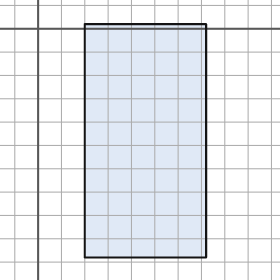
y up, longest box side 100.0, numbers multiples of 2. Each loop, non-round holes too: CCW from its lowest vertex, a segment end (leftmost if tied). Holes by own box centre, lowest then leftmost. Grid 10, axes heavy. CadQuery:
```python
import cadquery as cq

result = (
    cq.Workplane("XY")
    .moveTo(20.0, -98.0)
    .lineTo(72.0, -98.0)
    .lineTo(72.0, 2.0)
    .lineTo(20.0, 2.0)
    .close()
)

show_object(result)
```